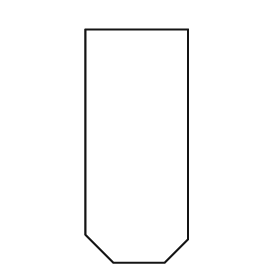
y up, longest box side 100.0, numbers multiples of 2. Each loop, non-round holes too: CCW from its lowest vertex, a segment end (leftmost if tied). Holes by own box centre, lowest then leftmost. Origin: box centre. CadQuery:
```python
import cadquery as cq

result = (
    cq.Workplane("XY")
    .moveTo(-10.0, -50.0)
    .lineTo(12.0, -50.0)
    .lineTo(22.0, -40.0)
    .lineTo(22.0, 50.0)
    .lineTo(-22.0, 50.0)
    .lineTo(-22.0, -38.0)
    .close()
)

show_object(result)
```